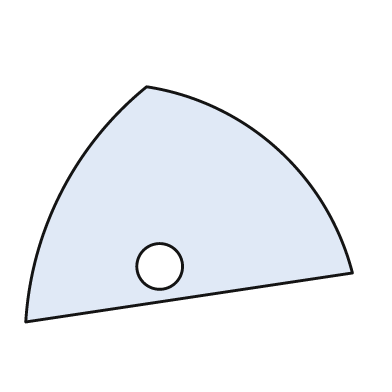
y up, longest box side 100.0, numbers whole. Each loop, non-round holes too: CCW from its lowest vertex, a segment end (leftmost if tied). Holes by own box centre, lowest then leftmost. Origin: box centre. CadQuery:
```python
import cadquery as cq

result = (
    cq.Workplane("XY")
    .moveTo(-50.0, -36.0)
    .lineTo(50.0, -21.0)
    .threePointArc((27.0, 17.0), (-13.0, 36.0))
    .threePointArc((-39.0, 4.0), (-50.0, -36.0))
    .close()
    .moveTo(-9.0, -19.0)
    .circle(7.0)
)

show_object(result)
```